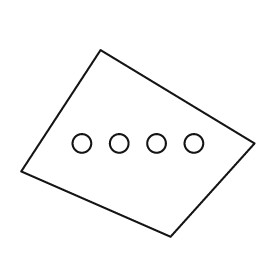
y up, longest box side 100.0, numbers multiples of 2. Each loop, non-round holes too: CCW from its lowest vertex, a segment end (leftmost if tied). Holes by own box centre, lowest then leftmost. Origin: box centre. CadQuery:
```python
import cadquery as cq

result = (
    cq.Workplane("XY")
    .moveTo(14.0, -40.0)
    .lineTo(50.0, 0.0)
    .lineTo(-16.0, 40.0)
    .lineTo(-50.0, -12.0)
    .close()
    .moveTo(-24.0, 0.0)
    .circle(4.0)
    .moveTo(-8.0, 0.0)
    .circle(4.0)
    .moveTo(8.0, 0.0)
    .circle(4.0)
    .moveTo(24.0, 0.0)
    .circle(4.0)
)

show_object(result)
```